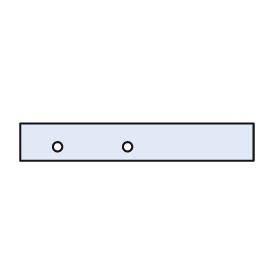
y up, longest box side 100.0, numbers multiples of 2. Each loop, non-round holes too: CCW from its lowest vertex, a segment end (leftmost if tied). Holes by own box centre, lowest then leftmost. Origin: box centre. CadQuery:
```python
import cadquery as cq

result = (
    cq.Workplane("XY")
    .moveTo(-50.0, -8.0)
    .lineTo(50.0, -8.0)
    .lineTo(50.0, 8.0)
    .lineTo(-50.0, 8.0)
    .close()
    .moveTo(-34.0, -2.0)
    .circle(2.0)
    .moveTo(-4.0, -2.0)
    .circle(2.0)
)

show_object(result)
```